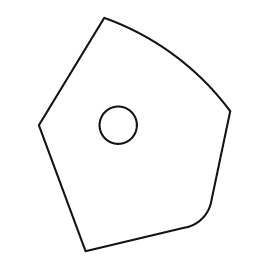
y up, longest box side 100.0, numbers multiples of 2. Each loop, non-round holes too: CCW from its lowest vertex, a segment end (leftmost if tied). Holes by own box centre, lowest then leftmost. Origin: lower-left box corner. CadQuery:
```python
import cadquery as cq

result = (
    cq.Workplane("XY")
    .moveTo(20.0, 0.0)
    .lineTo(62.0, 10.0)
    .threePointArc((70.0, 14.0), (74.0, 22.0))
    .lineTo(82.0, 60.0)
    .threePointArc((58.0, 84.0), (28.0, 100.0))
    .lineTo(0.0, 54.0)
    .close()
    .moveTo(34.0, 54.0)
    .circle(8.0)
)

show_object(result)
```